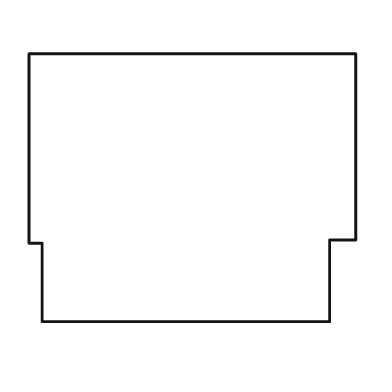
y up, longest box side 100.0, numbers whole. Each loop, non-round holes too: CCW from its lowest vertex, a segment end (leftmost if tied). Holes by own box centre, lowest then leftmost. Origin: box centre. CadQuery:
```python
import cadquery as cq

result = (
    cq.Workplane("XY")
    .moveTo(-46.0, -41.0)
    .lineTo(42.0, -41.0)
    .lineTo(42.0, -16.0)
    .lineTo(50.0, -16.0)
    .lineTo(50.0, 41.0)
    .lineTo(-50.0, 41.0)
    .lineTo(-50.0, -17.0)
    .lineTo(-46.0, -17.0)
    .close()
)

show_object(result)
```